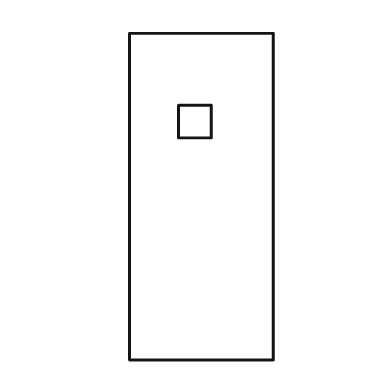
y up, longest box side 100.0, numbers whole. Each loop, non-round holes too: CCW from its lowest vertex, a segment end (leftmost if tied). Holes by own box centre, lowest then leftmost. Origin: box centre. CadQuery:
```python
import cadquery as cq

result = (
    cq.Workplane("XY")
    .moveTo(-22.0, -50.0)
    .lineTo(22.0, -50.0)
    .lineTo(22.0, 50.0)
    .lineTo(-22.0, 50.0)
    .close()
    .moveTo(-7.0, 18.0)
    .lineTo(3.0, 18.0)
    .lineTo(3.0, 28.0)
    .lineTo(-7.0, 28.0)
    .close()
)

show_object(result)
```